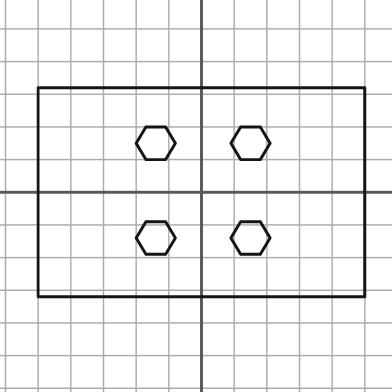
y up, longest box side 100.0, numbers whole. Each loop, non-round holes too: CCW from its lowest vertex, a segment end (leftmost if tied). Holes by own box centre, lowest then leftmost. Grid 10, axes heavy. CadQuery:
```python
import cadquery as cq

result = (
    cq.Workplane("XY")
    .moveTo(-50.0, -32.0)
    .lineTo(50.0, -32.0)
    .lineTo(50.0, 32.0)
    .lineTo(-50.0, 32.0)
    .close()
    .moveTo(-17.0, -19.0)
    .lineTo(-11.0, -19.0)
    .lineTo(-8.0, -14.0)
    .lineTo(-11.0, -9.0)
    .lineTo(-17.0, -9.0)
    .lineTo(-20.0, -14.0)
    .close()
    .moveTo(12.0, -19.0)
    .lineTo(18.0, -19.0)
    .lineTo(21.0, -14.0)
    .lineTo(18.0, -9.0)
    .lineTo(12.0, -9.0)
    .lineTo(9.0, -14.0)
    .close()
    .moveTo(-17.0, 10.0)
    .lineTo(-11.0, 10.0)
    .lineTo(-8.0, 15.0)
    .lineTo(-11.0, 20.0)
    .lineTo(-17.0, 20.0)
    .lineTo(-20.0, 15.0)
    .close()
    .moveTo(12.0, 10.0)
    .lineTo(18.0, 10.0)
    .lineTo(21.0, 15.0)
    .lineTo(18.0, 20.0)
    .lineTo(12.0, 20.0)
    .lineTo(9.0, 15.0)
    .close()
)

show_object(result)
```